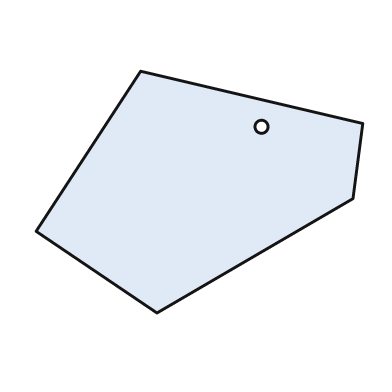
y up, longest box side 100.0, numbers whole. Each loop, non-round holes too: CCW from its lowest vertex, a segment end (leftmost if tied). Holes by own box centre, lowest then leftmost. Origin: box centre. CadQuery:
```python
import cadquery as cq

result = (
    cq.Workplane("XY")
    .moveTo(-13.0, -37.0)
    .lineTo(47.0, -2.0)
    .lineTo(50.0, 21.0)
    .lineTo(-18.0, 37.0)
    .lineTo(-50.0, -12.0)
    .close()
    .moveTo(19.0, 20.0)
    .circle(2.0)
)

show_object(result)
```